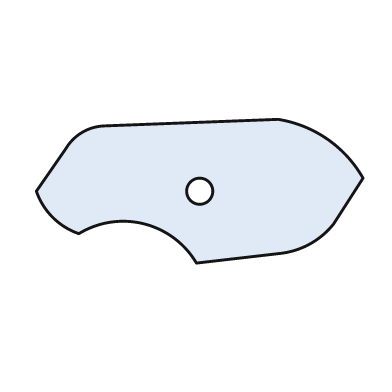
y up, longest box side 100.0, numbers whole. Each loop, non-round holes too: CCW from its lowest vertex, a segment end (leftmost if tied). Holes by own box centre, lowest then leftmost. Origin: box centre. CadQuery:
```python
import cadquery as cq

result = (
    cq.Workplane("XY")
    .moveTo(-1.0, -22.0)
    .lineTo(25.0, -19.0)
    .threePointArc((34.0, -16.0), (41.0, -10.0))
    .lineTo(50.0, 4.0)
    .threePointArc((39.0, 16.0), (24.0, 22.0))
    .lineTo(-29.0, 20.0)
    .threePointArc((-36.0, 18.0), (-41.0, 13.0))
    .lineTo(-50.0, 0.0)
    .threePointArc((-45.0, -8.0), (-37.0, -13.0))
    .threePointArc((-17.0, -10.0), (-1.0, -22.0))
    .close()
    .moveTo(0.0, 0.0)
    .circle(4.0)
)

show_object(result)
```